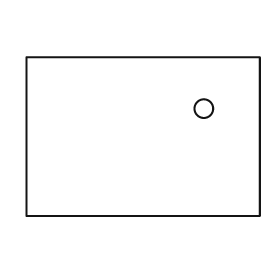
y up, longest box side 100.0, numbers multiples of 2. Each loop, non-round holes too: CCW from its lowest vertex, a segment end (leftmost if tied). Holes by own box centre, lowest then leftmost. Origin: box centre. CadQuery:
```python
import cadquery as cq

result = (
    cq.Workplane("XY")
    .moveTo(-50.0, -34.0)
    .lineTo(50.0, -34.0)
    .lineTo(50.0, 34.0)
    .lineTo(-50.0, 34.0)
    .close()
    .moveTo(26.0, 12.0)
    .circle(4.0)
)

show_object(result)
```